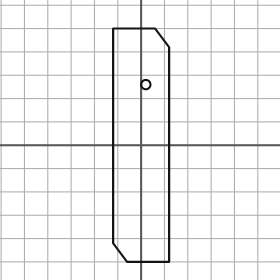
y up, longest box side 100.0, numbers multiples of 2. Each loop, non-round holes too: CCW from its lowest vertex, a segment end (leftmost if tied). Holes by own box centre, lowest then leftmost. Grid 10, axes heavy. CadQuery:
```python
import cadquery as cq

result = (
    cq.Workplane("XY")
    .moveTo(-6.0, -50.0)
    .lineTo(12.0, -50.0)
    .lineTo(12.0, 42.0)
    .lineTo(6.0, 50.0)
    .lineTo(-12.0, 50.0)
    .lineTo(-12.0, -42.0)
    .close()
    .moveTo(2.0, 26.0)
    .circle(2.0)
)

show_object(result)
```